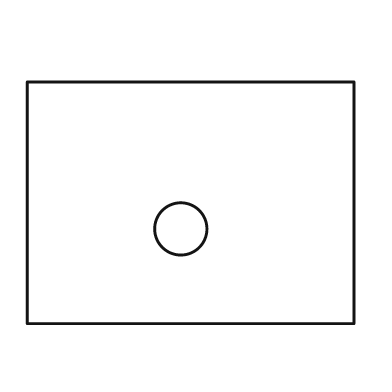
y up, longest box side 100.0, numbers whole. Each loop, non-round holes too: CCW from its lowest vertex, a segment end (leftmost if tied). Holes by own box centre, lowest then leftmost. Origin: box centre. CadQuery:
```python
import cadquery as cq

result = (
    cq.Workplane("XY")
    .moveTo(-50.0, -37.0)
    .lineTo(50.0, -37.0)
    .lineTo(50.0, 37.0)
    .lineTo(-50.0, 37.0)
    .close()
    .moveTo(-3.0, -8.0)
    .circle(8.0)
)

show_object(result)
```